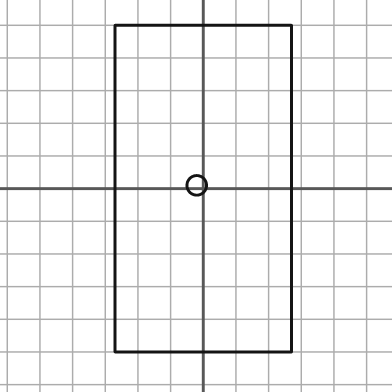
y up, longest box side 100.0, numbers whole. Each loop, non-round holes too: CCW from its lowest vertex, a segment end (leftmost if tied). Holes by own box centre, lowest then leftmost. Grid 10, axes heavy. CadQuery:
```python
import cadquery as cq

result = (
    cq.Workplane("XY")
    .moveTo(-27.0, -50.0)
    .lineTo(27.0, -50.0)
    .lineTo(27.0, 50.0)
    .lineTo(-27.0, 50.0)
    .close()
    .moveTo(-2.0, 1.0)
    .circle(3.0)
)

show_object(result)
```